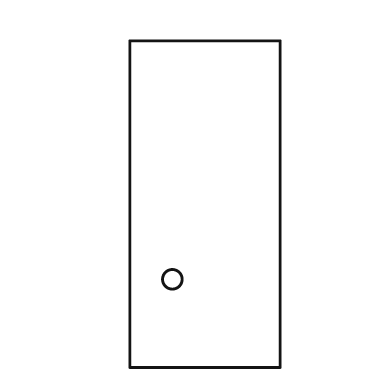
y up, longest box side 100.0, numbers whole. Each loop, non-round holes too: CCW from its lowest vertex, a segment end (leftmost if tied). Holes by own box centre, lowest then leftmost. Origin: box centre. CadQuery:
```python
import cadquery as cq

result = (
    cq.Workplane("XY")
    .moveTo(-23.0, -50.0)
    .lineTo(23.0, -50.0)
    .lineTo(23.0, 50.0)
    .lineTo(-23.0, 50.0)
    .close()
    .moveTo(-10.0, -23.0)
    .circle(3.0)
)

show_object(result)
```